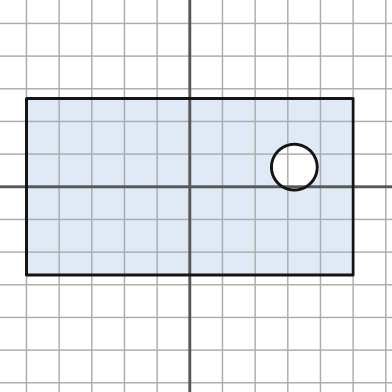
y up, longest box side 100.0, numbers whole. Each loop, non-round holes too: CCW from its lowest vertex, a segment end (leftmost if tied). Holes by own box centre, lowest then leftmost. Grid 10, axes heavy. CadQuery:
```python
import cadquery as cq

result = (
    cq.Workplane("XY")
    .moveTo(-50.0, -27.0)
    .lineTo(50.0, -27.0)
    .lineTo(50.0, 27.0)
    .lineTo(-50.0, 27.0)
    .close()
    .moveTo(32.0, 6.0)
    .circle(7.0)
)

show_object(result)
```